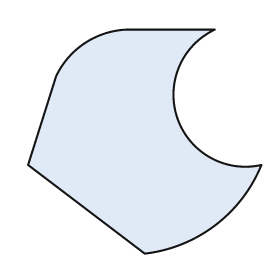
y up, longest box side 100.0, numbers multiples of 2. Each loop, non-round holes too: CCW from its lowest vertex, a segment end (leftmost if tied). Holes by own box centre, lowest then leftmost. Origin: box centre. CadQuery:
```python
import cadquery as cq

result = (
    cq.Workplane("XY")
    .moveTo(0.0, -48.0)
    .threePointArc((30.0, -36.0), (50.0, -10.0))
    .threePointArc((14.0, 10.0), (30.0, 48.0))
    .lineTo(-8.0, 48.0)
    .threePointArc((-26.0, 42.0), (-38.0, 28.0))
    .lineTo(-50.0, -10.0)
    .close()
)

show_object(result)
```